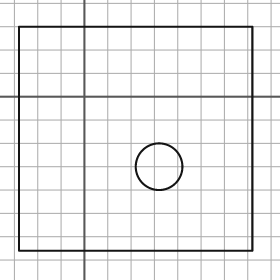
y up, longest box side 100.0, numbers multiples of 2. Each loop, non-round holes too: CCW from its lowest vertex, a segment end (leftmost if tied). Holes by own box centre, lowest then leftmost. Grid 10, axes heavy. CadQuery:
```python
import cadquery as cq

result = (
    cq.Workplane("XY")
    .moveTo(-28.0, -66.0)
    .lineTo(72.0, -66.0)
    .lineTo(72.0, 30.0)
    .lineTo(-28.0, 30.0)
    .close()
    .moveTo(32.0, -30.0)
    .circle(10.0)
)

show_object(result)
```